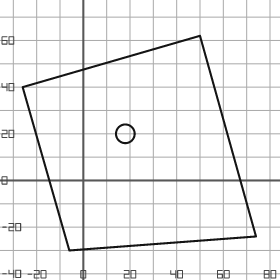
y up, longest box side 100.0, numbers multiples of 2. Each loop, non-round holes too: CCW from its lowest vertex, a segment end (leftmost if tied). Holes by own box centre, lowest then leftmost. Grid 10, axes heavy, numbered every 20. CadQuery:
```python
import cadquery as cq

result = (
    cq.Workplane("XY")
    .moveTo(-6.0, -30.0)
    .lineTo(74.0, -24.0)
    .lineTo(50.0, 62.0)
    .lineTo(-26.0, 40.0)
    .close()
    .moveTo(18.0, 20.0)
    .circle(4.0)
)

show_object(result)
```